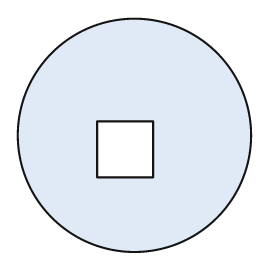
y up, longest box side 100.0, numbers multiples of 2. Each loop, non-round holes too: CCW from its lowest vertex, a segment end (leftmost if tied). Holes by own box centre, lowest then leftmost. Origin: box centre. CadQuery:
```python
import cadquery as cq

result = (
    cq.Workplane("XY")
    .moveTo(0.0, 0.0)
    .circle(50.0)
    .moveTo(-16.0, -18.0)
    .lineTo(8.0, -18.0)
    .lineTo(8.0, 6.0)
    .lineTo(-16.0, 6.0)
    .close()
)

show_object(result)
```